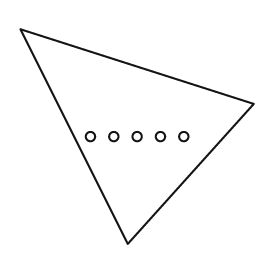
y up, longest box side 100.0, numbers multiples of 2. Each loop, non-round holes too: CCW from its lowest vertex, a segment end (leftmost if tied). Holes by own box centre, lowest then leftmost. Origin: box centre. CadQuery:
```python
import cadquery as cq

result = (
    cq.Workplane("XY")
    .moveTo(-4.0, -46.0)
    .lineTo(50.0, 14.0)
    .lineTo(-50.0, 46.0)
    .close()
    .moveTo(-20.0, 0.0)
    .circle(2.0)
    .moveTo(-10.0, 0.0)
    .circle(2.0)
    .moveTo(0.0, 0.0)
    .circle(2.0)
    .moveTo(10.0, 0.0)
    .circle(2.0)
    .moveTo(20.0, 0.0)
    .circle(2.0)
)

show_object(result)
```